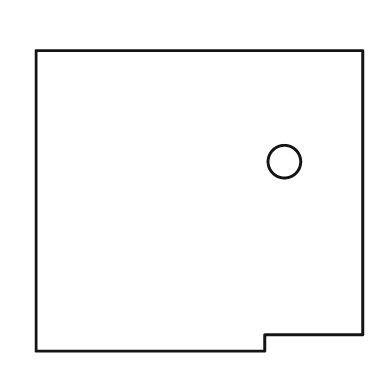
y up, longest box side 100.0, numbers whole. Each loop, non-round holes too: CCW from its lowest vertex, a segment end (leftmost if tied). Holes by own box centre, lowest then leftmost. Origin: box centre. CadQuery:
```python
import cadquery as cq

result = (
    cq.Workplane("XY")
    .moveTo(-50.0, -46.0)
    .lineTo(20.0, -46.0)
    .lineTo(20.0, -41.0)
    .lineTo(50.0, -41.0)
    .lineTo(50.0, 46.0)
    .lineTo(-50.0, 46.0)
    .close()
    .moveTo(26.0, 12.0)
    .circle(5.0)
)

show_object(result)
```